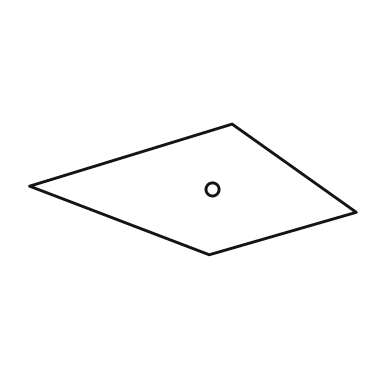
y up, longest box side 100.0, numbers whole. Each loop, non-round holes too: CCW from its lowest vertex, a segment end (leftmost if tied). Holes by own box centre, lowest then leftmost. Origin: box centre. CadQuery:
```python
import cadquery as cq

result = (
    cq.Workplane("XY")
    .moveTo(5.0, -20.0)
    .lineTo(50.0, -7.0)
    .lineTo(12.0, 20.0)
    .lineTo(-50.0, 1.0)
    .close()
    .moveTo(6.0, 0.0)
    .circle(2.0)
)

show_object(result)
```